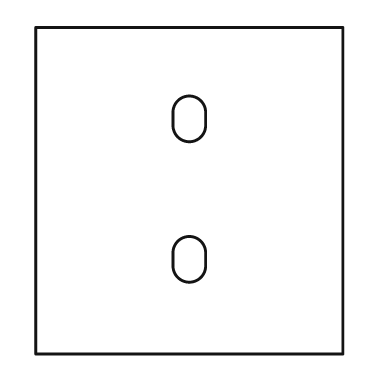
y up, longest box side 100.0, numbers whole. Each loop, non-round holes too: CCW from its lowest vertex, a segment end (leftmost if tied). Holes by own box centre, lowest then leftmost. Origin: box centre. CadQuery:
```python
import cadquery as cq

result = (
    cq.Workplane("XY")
    .moveTo(-47.0, -50.0)
    .lineTo(47.0, -50.0)
    .lineTo(47.0, 50.0)
    .lineTo(-47.0, 50.0)
    .close()
    .moveTo(-5.0, -23.0)
    .threePointArc((0.0, -28.0), (5.0, -23.0))
    .lineTo(5.0, -19.0)
    .threePointArc((0.0, -14.0), (-5.0, -19.0))
    .close()
    .moveTo(-5.0, 20.0)
    .threePointArc((0.0, 15.0), (5.0, 20.0))
    .lineTo(5.0, 24.0)
    .threePointArc((0.0, 29.0), (-5.0, 24.0))
    .close()
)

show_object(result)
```